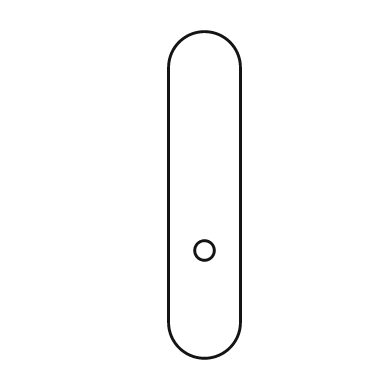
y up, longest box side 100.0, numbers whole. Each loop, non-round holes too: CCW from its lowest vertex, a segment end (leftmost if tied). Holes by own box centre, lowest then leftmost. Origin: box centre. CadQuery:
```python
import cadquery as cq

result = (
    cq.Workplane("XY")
    .moveTo(-11.0, -39.0)
    .threePointArc((0.0, -50.0), (11.0, -39.0))
    .lineTo(11.0, 39.0)
    .threePointArc((0.0, 50.0), (-11.0, 39.0))
    .close()
    .moveTo(0.0, -17.0)
    .circle(3.0)
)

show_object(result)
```